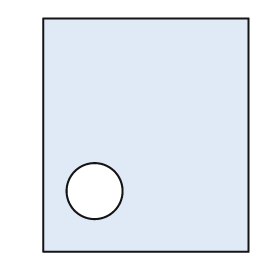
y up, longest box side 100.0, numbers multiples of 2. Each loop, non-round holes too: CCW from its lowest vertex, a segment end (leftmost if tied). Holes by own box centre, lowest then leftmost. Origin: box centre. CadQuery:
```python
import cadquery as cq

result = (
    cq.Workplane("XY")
    .moveTo(-44.0, -50.0)
    .lineTo(44.0, -50.0)
    .lineTo(44.0, 50.0)
    .lineTo(-44.0, 50.0)
    .close()
    .moveTo(-22.0, -24.0)
    .circle(12.0)
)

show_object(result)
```